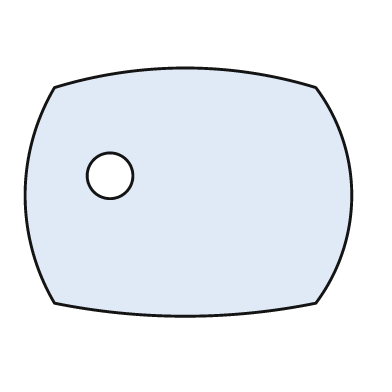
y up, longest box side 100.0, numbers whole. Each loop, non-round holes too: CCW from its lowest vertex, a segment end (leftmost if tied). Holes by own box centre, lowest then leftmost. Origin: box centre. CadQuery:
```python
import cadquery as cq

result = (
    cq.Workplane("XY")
    .moveTo(-41.0, -34.0)
    .threePointArc((-1.0, -38.0), (39.0, -34.0))
    .threePointArc((50.0, -1.0), (39.0, 32.0))
    .threePointArc((-1.0, 38.0), (-41.0, 32.0))
    .threePointArc((-50.0, -1.0), (-41.0, -34.0))
    .close()
    .moveTo(-24.0, 5.0)
    .circle(7.0)
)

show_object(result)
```